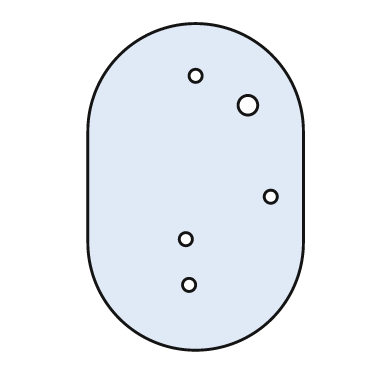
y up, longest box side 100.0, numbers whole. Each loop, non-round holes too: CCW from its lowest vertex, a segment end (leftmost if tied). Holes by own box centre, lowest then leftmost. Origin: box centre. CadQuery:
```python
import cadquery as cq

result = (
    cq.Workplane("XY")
    .moveTo(-33.0, -17.0)
    .threePointArc((0.0, -50.0), (33.0, -17.0))
    .lineTo(33.0, 17.0)
    .threePointArc((0.0, 50.0), (-33.0, 17.0))
    .close()
    .moveTo(-2.0, -30.0)
    .circle(2.0)
    .moveTo(-3.0, -16.0)
    .circle(2.0)
    .moveTo(23.0, -3.0)
    .circle(2.0)
    .moveTo(16.0, 25.0)
    .circle(3.0)
    .moveTo(0.0, 34.0)
    .circle(2.0)
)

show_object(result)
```